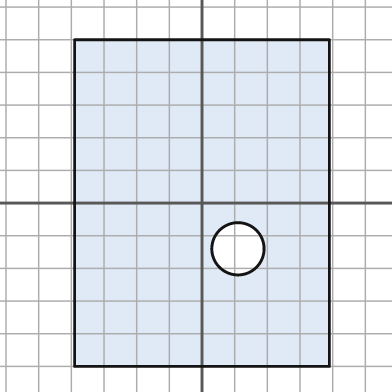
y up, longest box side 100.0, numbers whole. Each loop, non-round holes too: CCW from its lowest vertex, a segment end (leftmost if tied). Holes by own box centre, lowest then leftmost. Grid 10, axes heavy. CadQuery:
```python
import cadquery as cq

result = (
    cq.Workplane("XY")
    .moveTo(-39.0, -50.0)
    .lineTo(39.0, -50.0)
    .lineTo(39.0, 50.0)
    .lineTo(-39.0, 50.0)
    .close()
    .moveTo(11.0, -14.0)
    .circle(8.0)
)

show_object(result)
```